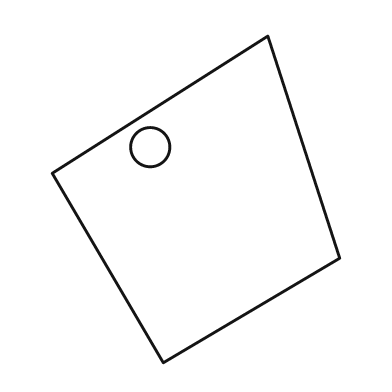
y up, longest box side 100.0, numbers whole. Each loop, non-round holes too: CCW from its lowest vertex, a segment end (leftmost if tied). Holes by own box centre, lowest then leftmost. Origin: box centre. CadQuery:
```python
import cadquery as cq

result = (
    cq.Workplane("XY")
    .moveTo(-10.0, -50.0)
    .lineTo(44.0, -18.0)
    .lineTo(22.0, 50.0)
    .lineTo(-44.0, 8.0)
    .close()
    .moveTo(-14.0, 16.0)
    .circle(6.0)
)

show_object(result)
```